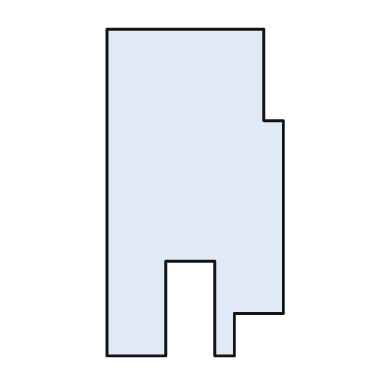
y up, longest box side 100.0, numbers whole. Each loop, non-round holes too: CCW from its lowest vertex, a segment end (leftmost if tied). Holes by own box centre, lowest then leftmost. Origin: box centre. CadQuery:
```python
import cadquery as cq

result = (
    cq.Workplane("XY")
    .moveTo(-27.0, -50.0)
    .lineTo(-9.0, -50.0)
    .lineTo(-9.0, -21.0)
    .lineTo(6.0, -21.0)
    .lineTo(6.0, -50.0)
    .lineTo(12.0, -50.0)
    .lineTo(12.0, -37.0)
    .lineTo(27.0, -37.0)
    .lineTo(27.0, 22.0)
    .lineTo(21.0, 22.0)
    .lineTo(21.0, 50.0)
    .lineTo(-27.0, 50.0)
    .close()
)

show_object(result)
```